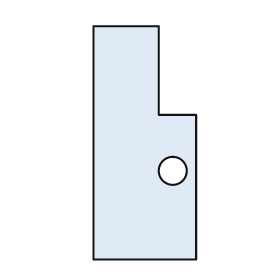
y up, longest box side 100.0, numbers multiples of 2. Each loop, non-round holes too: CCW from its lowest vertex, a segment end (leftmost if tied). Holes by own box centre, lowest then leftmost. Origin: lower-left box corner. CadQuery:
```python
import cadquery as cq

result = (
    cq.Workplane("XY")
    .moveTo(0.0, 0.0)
    .lineTo(44.0, 0.0)
    .lineTo(44.0, 62.0)
    .lineTo(28.0, 62.0)
    .lineTo(28.0, 100.0)
    .lineTo(0.0, 100.0)
    .close()
    .moveTo(34.0, 38.0)
    .circle(6.0)
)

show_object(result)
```